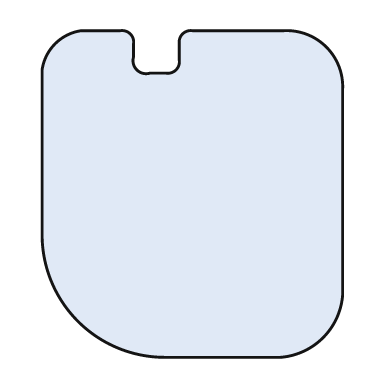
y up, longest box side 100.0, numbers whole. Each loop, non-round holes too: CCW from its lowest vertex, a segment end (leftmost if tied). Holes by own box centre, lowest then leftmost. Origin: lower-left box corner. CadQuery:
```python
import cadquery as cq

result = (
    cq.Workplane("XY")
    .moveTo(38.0, 0.0)
    .lineTo(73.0, 0.0)
    .threePointArc((86.0, 6.0), (92.0, 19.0))
    .lineTo(92.0, 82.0)
    .threePointArc((87.0, 95.0), (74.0, 100.0))
    .lineTo(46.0, 100.0)
    .threePointArc((43.0, 99.0), (42.0, 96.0))
    .lineTo(42.0, 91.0)
    .threePointArc((41.0, 88.0), (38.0, 87.0))
    .lineTo(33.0, 87.0)
    .threePointArc((29.0, 88.0), (28.0, 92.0))
    .lineTo(28.0, 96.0)
    .threePointArc((27.0, 99.0), (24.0, 100.0))
    .lineTo(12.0, 100.0)
    .threePointArc((4.0, 96.0), (0.0, 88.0))
    .lineTo(0.0, 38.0)
    .threePointArc((11.0, 11.0), (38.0, 0.0))
    .close()
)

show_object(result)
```